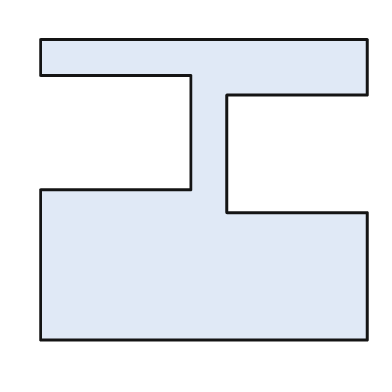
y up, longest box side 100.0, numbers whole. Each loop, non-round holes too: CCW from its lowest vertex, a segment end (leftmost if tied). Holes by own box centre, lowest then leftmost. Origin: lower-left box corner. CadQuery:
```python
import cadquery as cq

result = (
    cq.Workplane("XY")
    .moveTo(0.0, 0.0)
    .lineTo(100.0, 0.0)
    .lineTo(100.0, 39.0)
    .lineTo(57.0, 39.0)
    .lineTo(57.0, 75.0)
    .lineTo(100.0, 75.0)
    .lineTo(100.0, 92.0)
    .lineTo(0.0, 92.0)
    .lineTo(0.0, 81.0)
    .lineTo(46.0, 81.0)
    .lineTo(46.0, 46.0)
    .lineTo(0.0, 46.0)
    .close()
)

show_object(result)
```